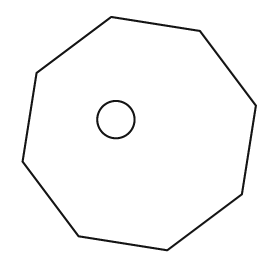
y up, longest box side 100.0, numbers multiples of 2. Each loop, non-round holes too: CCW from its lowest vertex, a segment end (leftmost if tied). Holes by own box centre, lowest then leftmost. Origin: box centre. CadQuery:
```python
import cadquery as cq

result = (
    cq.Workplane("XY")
    .moveTo(12.0, -50.0)
    .lineTo(44.0, -26.0)
    .lineTo(50.0, 12.0)
    .lineTo(26.0, 44.0)
    .lineTo(-12.0, 50.0)
    .lineTo(-44.0, 26.0)
    .lineTo(-50.0, -12.0)
    .lineTo(-26.0, -44.0)
    .close()
    .moveTo(-10.0, 6.0)
    .circle(8.0)
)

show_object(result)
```